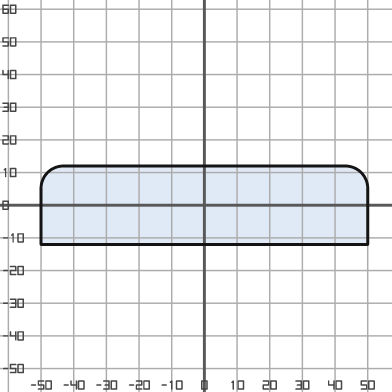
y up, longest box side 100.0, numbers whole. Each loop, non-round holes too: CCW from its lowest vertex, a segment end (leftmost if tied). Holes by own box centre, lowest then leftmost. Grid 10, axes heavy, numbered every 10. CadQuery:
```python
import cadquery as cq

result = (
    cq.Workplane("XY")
    .moveTo(-50.0, -12.0)
    .lineTo(50.0, -12.0)
    .lineTo(50.0, 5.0)
    .threePointArc((48.0, 10.0), (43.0, 12.0))
    .lineTo(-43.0, 12.0)
    .threePointArc((-48.0, 10.0), (-50.0, 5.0))
    .close()
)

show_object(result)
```